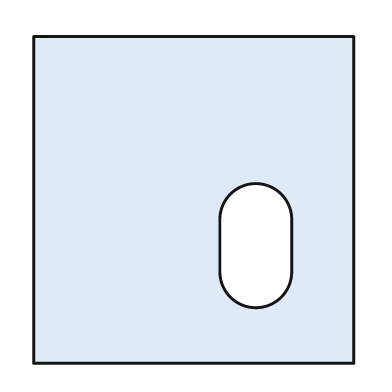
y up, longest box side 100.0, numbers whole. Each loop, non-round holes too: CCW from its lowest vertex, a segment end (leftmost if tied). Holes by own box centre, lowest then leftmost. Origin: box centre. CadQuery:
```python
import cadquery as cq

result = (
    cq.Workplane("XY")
    .moveTo(-49.0, -50.0)
    .lineTo(49.0, -50.0)
    .lineTo(49.0, 50.0)
    .lineTo(-49.0, 50.0)
    .close()
    .moveTo(8.0, -22.0)
    .threePointArc((19.0, -33.0), (30.0, -22.0))
    .lineTo(30.0, -6.0)
    .threePointArc((19.0, 5.0), (8.0, -6.0))
    .close()
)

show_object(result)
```